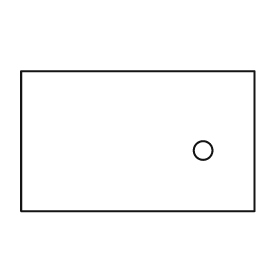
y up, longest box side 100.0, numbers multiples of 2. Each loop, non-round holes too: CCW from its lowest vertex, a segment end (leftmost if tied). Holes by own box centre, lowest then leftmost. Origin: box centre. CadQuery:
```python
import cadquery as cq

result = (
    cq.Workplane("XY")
    .moveTo(-50.0, -30.0)
    .lineTo(50.0, -30.0)
    .lineTo(50.0, 30.0)
    .lineTo(-50.0, 30.0)
    .close()
    .moveTo(28.0, -4.0)
    .circle(4.0)
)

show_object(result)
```